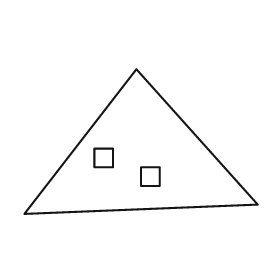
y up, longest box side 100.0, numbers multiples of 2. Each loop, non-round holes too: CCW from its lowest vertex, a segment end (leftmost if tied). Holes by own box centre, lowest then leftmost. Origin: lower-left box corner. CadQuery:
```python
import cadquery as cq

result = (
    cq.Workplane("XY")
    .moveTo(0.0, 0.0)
    .lineTo(100.0, 4.0)
    .lineTo(48.0, 62.0)
    .close()
    .moveTo(50.0, 12.0)
    .lineTo(58.0, 12.0)
    .lineTo(58.0, 20.0)
    .lineTo(50.0, 20.0)
    .close()
    .moveTo(30.0, 20.0)
    .lineTo(38.0, 20.0)
    .lineTo(38.0, 28.0)
    .lineTo(30.0, 28.0)
    .close()
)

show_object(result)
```